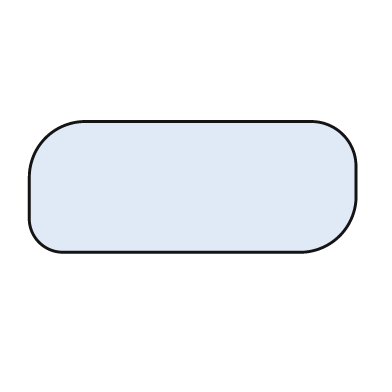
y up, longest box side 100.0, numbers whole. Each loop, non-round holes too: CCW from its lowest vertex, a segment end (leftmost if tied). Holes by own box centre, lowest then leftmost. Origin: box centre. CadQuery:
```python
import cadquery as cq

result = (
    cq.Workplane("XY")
    .moveTo(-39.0, -20.0)
    .lineTo(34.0, -20.0)
    .threePointArc((45.0, -15.0), (50.0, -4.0))
    .lineTo(50.0, 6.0)
    .threePointArc((46.0, 16.0), (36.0, 20.0))
    .lineTo(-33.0, 20.0)
    .threePointArc((-45.0, 15.0), (-50.0, 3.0))
    .lineTo(-50.0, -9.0)
    .threePointArc((-47.0, -17.0), (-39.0, -20.0))
    .close()
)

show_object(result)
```